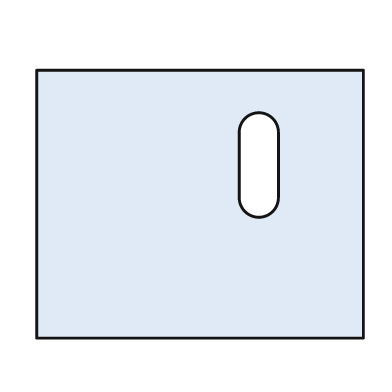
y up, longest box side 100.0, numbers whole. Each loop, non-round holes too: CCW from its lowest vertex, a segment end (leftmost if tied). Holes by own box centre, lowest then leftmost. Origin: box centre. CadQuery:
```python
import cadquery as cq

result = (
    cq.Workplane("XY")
    .moveTo(-50.0, -41.0)
    .lineTo(50.0, -41.0)
    .lineTo(50.0, 41.0)
    .lineTo(-50.0, 41.0)
    .close()
    .moveTo(12.0, 2.0)
    .threePointArc((18.0, -4.0), (24.0, 2.0))
    .lineTo(24.0, 22.0)
    .threePointArc((18.0, 28.0), (12.0, 22.0))
    .close()
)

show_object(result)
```